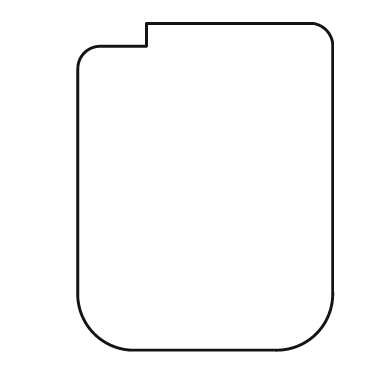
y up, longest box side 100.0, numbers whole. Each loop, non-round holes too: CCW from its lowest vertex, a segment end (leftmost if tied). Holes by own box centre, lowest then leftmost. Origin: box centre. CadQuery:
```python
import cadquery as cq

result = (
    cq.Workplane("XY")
    .moveTo(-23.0, -50.0)
    .lineTo(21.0, -50.0)
    .threePointArc((34.0, -45.0), (39.0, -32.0))
    .lineTo(39.0, 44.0)
    .threePointArc((37.0, 48.0), (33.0, 50.0))
    .lineTo(-18.0, 50.0)
    .lineTo(-18.0, 43.0)
    .lineTo(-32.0, 43.0)
    .threePointArc((-37.0, 41.0), (-39.0, 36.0))
    .lineTo(-39.0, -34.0)
    .threePointArc((-34.0, -45.0), (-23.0, -50.0))
    .close()
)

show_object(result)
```